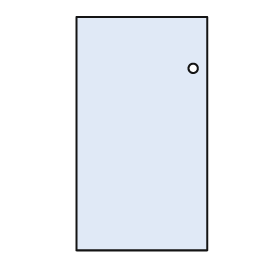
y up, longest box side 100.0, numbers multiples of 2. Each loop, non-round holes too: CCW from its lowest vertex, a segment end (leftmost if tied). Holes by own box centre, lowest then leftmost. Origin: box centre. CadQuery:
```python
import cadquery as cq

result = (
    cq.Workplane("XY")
    .moveTo(-28.0, -50.0)
    .lineTo(28.0, -50.0)
    .lineTo(28.0, 50.0)
    .lineTo(-28.0, 50.0)
    .close()
    .moveTo(22.0, 28.0)
    .circle(2.0)
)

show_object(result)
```